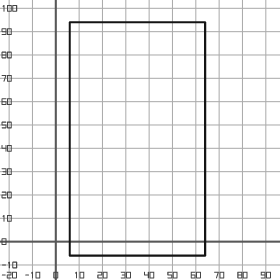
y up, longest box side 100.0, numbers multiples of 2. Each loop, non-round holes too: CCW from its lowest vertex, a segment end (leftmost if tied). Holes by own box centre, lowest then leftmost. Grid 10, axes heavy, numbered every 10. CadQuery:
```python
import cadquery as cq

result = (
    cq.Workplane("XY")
    .moveTo(6.0, -6.0)
    .lineTo(64.0, -6.0)
    .lineTo(64.0, 94.0)
    .lineTo(6.0, 94.0)
    .close()
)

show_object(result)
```